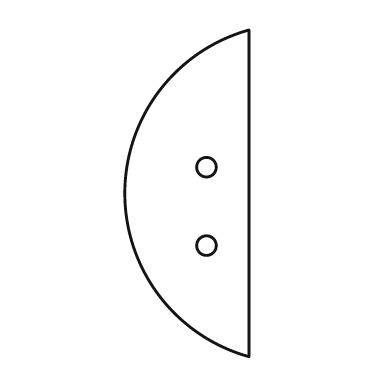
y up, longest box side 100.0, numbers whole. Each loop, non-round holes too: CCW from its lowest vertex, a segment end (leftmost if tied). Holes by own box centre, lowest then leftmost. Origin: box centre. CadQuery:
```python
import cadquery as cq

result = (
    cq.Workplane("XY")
    .moveTo(19.0, -50.0)
    .lineTo(19.0, 50.0)
    .threePointArc((-19.0, 0.0), (19.0, -50.0))
    .close()
    .moveTo(6.0, -16.0)
    .circle(3.0)
    .moveTo(6.0, 8.0)
    .circle(3.0)
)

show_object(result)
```